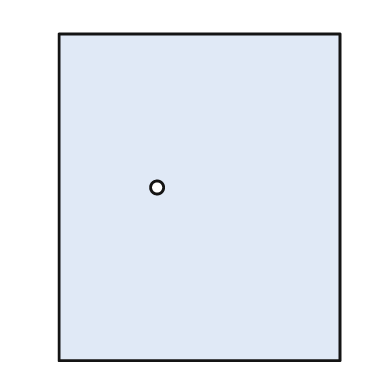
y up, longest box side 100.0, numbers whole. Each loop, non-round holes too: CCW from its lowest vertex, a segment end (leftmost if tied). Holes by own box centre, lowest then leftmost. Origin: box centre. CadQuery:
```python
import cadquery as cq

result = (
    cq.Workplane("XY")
    .moveTo(-43.0, -50.0)
    .lineTo(43.0, -50.0)
    .lineTo(43.0, 50.0)
    .lineTo(-43.0, 50.0)
    .close()
    .moveTo(-13.0, 3.0)
    .circle(2.0)
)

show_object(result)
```